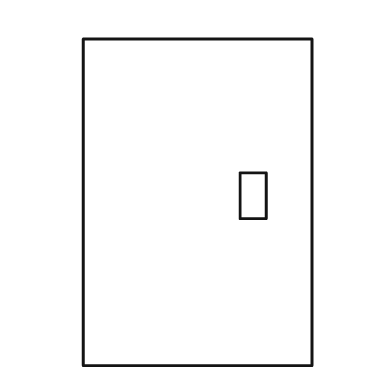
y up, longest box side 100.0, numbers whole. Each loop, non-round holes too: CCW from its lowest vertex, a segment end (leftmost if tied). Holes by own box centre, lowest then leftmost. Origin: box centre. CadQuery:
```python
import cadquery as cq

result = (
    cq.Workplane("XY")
    .moveTo(-35.0, -50.0)
    .lineTo(35.0, -50.0)
    .lineTo(35.0, 50.0)
    .lineTo(-35.0, 50.0)
    .close()
    .moveTo(13.0, -5.0)
    .lineTo(21.0, -5.0)
    .lineTo(21.0, 9.0)
    .lineTo(13.0, 9.0)
    .close()
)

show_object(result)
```